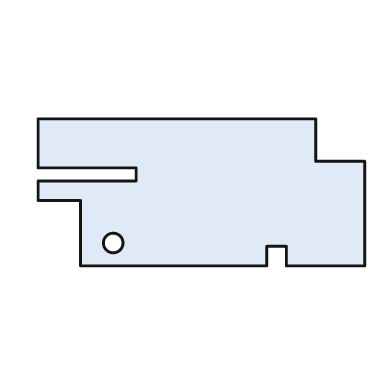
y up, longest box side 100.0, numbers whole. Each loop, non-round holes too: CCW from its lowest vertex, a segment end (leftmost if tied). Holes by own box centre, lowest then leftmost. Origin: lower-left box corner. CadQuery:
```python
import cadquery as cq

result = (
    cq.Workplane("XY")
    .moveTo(13.0, 0.0)
    .lineTo(70.0, 0.0)
    .lineTo(70.0, 6.0)
    .lineTo(76.0, 6.0)
    .lineTo(76.0, 0.0)
    .lineTo(100.0, 0.0)
    .lineTo(100.0, 32.0)
    .lineTo(85.0, 32.0)
    .lineTo(85.0, 45.0)
    .lineTo(0.0, 45.0)
    .lineTo(0.0, 30.0)
    .lineTo(30.0, 30.0)
    .lineTo(30.0, 26.0)
    .lineTo(0.0, 26.0)
    .lineTo(0.0, 20.0)
    .lineTo(13.0, 20.0)
    .close()
    .moveTo(23.0, 7.0)
    .circle(3.0)
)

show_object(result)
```